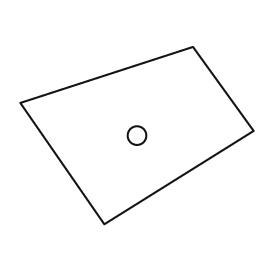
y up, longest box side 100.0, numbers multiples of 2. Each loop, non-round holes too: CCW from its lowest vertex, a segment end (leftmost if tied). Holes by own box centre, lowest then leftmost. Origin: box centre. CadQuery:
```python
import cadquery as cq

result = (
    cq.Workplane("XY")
    .moveTo(-14.0, -38.0)
    .lineTo(50.0, 2.0)
    .lineTo(24.0, 38.0)
    .lineTo(-50.0, 14.0)
    .close()
    .moveTo(0.0, 0.0)
    .circle(4.0)
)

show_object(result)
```